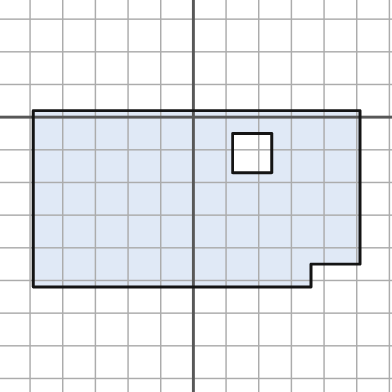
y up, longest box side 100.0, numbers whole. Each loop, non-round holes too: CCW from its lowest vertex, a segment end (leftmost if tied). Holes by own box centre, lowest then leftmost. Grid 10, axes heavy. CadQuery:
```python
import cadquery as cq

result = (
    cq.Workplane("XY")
    .moveTo(-49.0, -52.0)
    .lineTo(36.0, -52.0)
    .lineTo(36.0, -45.0)
    .lineTo(51.0, -45.0)
    .lineTo(51.0, 2.0)
    .lineTo(-49.0, 2.0)
    .close()
    .moveTo(12.0, -17.0)
    .lineTo(24.0, -17.0)
    .lineTo(24.0, -5.0)
    .lineTo(12.0, -5.0)
    .close()
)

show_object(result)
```